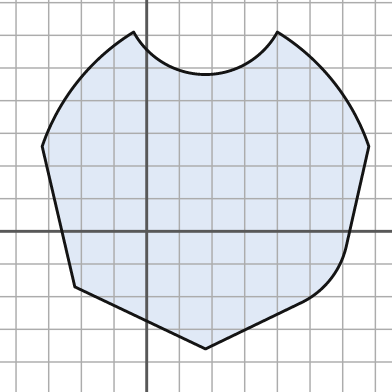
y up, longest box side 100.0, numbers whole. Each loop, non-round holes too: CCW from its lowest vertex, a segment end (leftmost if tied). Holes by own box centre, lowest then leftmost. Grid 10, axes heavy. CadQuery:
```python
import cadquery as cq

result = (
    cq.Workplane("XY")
    .moveTo(18.0, -36.0)
    .lineTo(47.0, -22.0)
    .threePointArc((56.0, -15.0), (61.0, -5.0))
    .lineTo(68.0, 26.0)
    .threePointArc((57.0, 46.0), (40.0, 61.0))
    .threePointArc((18.0, 48.0), (-4.0, 61.0))
    .threePointArc((-21.0, 46.0), (-32.0, 26.0))
    .lineTo(-22.0, -17.0)
    .close()
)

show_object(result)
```